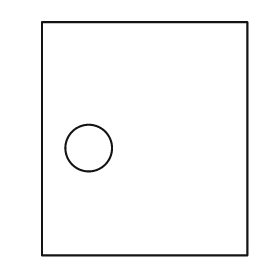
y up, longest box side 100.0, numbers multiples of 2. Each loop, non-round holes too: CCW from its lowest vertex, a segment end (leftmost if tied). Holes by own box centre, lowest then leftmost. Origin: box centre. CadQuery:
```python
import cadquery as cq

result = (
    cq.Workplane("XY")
    .moveTo(-44.0, -50.0)
    .lineTo(44.0, -50.0)
    .lineTo(44.0, 50.0)
    .lineTo(-44.0, 50.0)
    .close()
    .moveTo(-24.0, -4.0)
    .circle(10.0)
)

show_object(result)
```